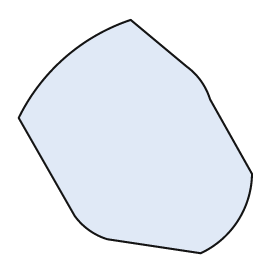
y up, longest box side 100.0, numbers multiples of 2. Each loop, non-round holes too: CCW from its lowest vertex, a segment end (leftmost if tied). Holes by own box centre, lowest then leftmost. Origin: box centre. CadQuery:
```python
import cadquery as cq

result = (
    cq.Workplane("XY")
    .moveTo(28.0, -50.0)
    .threePointArc((44.0, -36.0), (50.0, -16.0))
    .lineTo(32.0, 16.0)
    .threePointArc((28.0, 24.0), (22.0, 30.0))
    .lineTo(-2.0, 50.0)
    .threePointArc((-30.0, 34.0), (-50.0, 8.0))
    .lineTo(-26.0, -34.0)
    .threePointArc((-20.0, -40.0), (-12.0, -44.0))
    .close()
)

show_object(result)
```